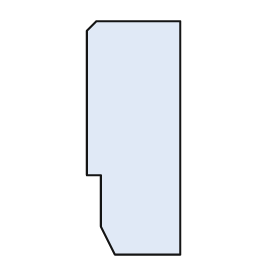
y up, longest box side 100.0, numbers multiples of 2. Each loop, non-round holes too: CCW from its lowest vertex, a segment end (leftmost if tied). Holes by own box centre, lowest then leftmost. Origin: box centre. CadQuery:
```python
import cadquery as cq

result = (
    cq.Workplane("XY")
    .moveTo(-8.0, -50.0)
    .lineTo(20.0, -50.0)
    .lineTo(20.0, 50.0)
    .lineTo(-16.0, 50.0)
    .lineTo(-20.0, 46.0)
    .lineTo(-20.0, -16.0)
    .lineTo(-14.0, -16.0)
    .lineTo(-14.0, -38.0)
    .close()
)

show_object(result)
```